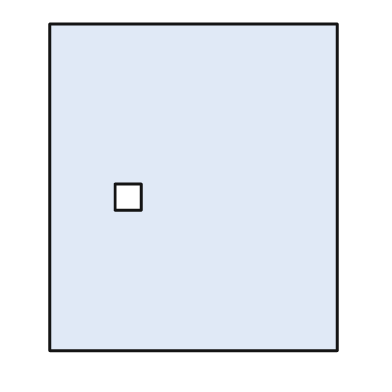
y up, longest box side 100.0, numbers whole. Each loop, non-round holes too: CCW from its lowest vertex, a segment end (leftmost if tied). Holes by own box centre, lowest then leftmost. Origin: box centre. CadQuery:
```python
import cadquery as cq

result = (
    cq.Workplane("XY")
    .moveTo(-44.0, -50.0)
    .lineTo(44.0, -50.0)
    .lineTo(44.0, 50.0)
    .lineTo(-44.0, 50.0)
    .close()
    .moveTo(-24.0, -7.0)
    .lineTo(-16.0, -7.0)
    .lineTo(-16.0, 1.0)
    .lineTo(-24.0, 1.0)
    .close()
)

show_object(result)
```